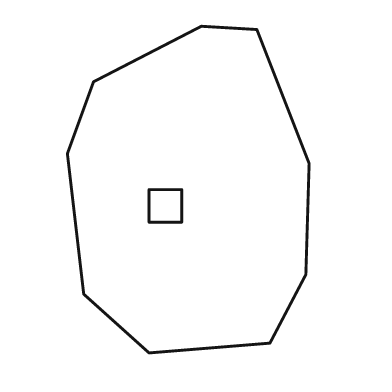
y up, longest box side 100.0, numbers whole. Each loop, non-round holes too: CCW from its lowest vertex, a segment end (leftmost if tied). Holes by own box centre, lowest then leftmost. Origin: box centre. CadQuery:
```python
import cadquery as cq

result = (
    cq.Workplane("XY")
    .moveTo(-12.0, -50.0)
    .lineTo(25.0, -47.0)
    .lineTo(36.0, -26.0)
    .lineTo(37.0, 8.0)
    .lineTo(21.0, 49.0)
    .lineTo(4.0, 50.0)
    .lineTo(-29.0, 33.0)
    .lineTo(-37.0, 11.0)
    .lineTo(-32.0, -32.0)
    .close()
    .moveTo(-12.0, -10.0)
    .lineTo(-2.0, -10.0)
    .lineTo(-2.0, 0.0)
    .lineTo(-12.0, 0.0)
    .close()
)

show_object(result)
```